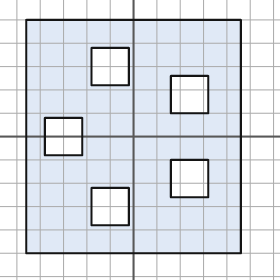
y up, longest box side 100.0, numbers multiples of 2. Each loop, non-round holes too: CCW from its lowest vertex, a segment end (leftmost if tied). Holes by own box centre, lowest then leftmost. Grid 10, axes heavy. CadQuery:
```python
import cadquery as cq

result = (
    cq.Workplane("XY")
    .moveTo(-46.0, -50.0)
    .lineTo(46.0, -50.0)
    .lineTo(46.0, 50.0)
    .lineTo(-46.0, 50.0)
    .close()
    .moveTo(-18.0, -38.0)
    .lineTo(-2.0, -38.0)
    .lineTo(-2.0, -22.0)
    .lineTo(-18.0, -22.0)
    .close()
    .moveTo(16.0, -26.0)
    .lineTo(32.0, -26.0)
    .lineTo(32.0, -10.0)
    .lineTo(16.0, -10.0)
    .close()
    .moveTo(-38.0, -8.0)
    .lineTo(-22.0, -8.0)
    .lineTo(-22.0, 8.0)
    .lineTo(-38.0, 8.0)
    .close()
    .moveTo(16.0, 10.0)
    .lineTo(32.0, 10.0)
    .lineTo(32.0, 26.0)
    .lineTo(16.0, 26.0)
    .close()
    .moveTo(-18.0, 22.0)
    .lineTo(-2.0, 22.0)
    .lineTo(-2.0, 38.0)
    .lineTo(-18.0, 38.0)
    .close()
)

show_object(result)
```